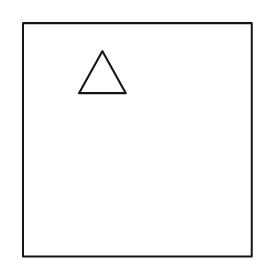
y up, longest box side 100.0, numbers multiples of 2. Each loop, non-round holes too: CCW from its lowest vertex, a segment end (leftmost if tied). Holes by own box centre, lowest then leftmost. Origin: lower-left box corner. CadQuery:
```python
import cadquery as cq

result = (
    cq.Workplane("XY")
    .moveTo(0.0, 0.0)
    .lineTo(98.0, 0.0)
    .lineTo(98.0, 100.0)
    .lineTo(0.0, 100.0)
    .close()
    .moveTo(24.0, 70.0)
    .lineTo(44.0, 70.0)
    .lineTo(34.0, 88.0)
    .close()
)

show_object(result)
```